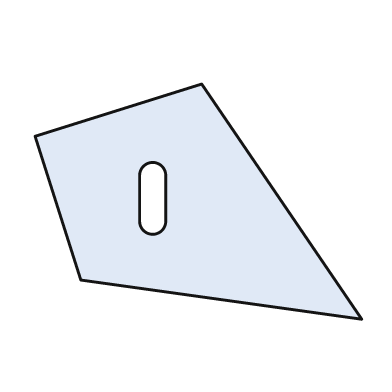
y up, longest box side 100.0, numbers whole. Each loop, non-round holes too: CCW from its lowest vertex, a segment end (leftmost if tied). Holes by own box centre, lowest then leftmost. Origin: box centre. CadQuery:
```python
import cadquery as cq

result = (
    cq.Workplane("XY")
    .moveTo(50.0, -36.0)
    .lineTo(1.0, 36.0)
    .lineTo(-50.0, 20.0)
    .lineTo(-36.0, -24.0)
    .close()
    .moveTo(-18.0, -6.0)
    .threePointArc((-14.0, -10.0), (-10.0, -6.0))
    .lineTo(-10.0, 8.0)
    .threePointArc((-14.0, 12.0), (-18.0, 8.0))
    .close()
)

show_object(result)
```